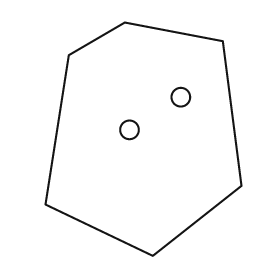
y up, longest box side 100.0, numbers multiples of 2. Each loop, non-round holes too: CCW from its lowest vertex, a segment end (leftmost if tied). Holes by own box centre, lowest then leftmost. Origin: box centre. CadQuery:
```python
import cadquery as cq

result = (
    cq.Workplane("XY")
    .moveTo(4.0, -50.0)
    .lineTo(42.0, -20.0)
    .lineTo(34.0, 42.0)
    .lineTo(-8.0, 50.0)
    .lineTo(-32.0, 36.0)
    .lineTo(-42.0, -28.0)
    .close()
    .moveTo(-6.0, 4.0)
    .circle(4.0)
    .moveTo(16.0, 18.0)
    .circle(4.0)
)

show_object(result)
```